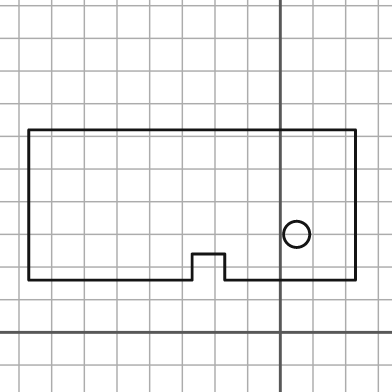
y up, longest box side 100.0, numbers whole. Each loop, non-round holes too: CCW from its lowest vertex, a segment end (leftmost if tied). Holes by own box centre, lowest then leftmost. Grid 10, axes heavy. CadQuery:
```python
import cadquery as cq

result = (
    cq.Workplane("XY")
    .moveTo(-77.0, 16.0)
    .lineTo(-27.0, 16.0)
    .lineTo(-27.0, 24.0)
    .lineTo(-17.0, 24.0)
    .lineTo(-17.0, 16.0)
    .lineTo(23.0, 16.0)
    .lineTo(23.0, 62.0)
    .lineTo(-77.0, 62.0)
    .close()
    .moveTo(5.0, 30.0)
    .circle(4.0)
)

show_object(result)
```